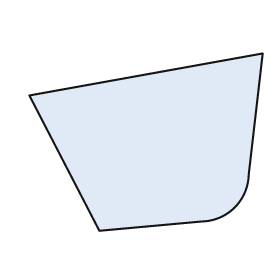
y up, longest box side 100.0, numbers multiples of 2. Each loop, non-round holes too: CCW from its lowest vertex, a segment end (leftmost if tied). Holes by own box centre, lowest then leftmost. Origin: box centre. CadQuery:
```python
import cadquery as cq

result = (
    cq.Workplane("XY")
    .moveTo(-20.0, -38.0)
    .lineTo(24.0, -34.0)
    .threePointArc((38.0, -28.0), (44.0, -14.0))
    .lineTo(50.0, 38.0)
    .lineTo(-50.0, 20.0)
    .close()
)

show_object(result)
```